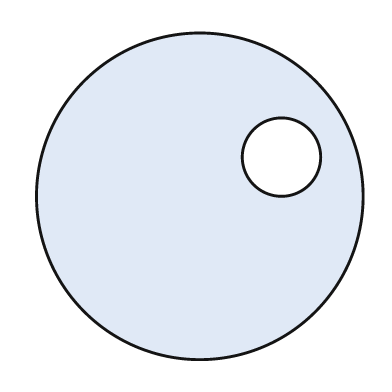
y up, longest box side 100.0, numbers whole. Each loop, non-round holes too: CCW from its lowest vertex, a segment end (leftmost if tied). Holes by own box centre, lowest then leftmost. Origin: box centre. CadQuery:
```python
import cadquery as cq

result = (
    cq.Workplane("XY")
    .moveTo(0.0, 0.0)
    .circle(50.0)
    .moveTo(25.0, 12.0)
    .circle(12.0)
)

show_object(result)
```